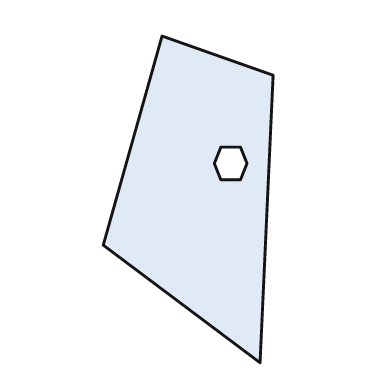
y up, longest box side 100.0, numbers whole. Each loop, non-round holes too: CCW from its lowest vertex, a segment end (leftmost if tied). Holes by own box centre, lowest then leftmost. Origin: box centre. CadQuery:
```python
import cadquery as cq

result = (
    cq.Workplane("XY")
    .moveTo(22.0, -50.0)
    .lineTo(26.0, 38.0)
    .lineTo(-8.0, 50.0)
    .lineTo(-26.0, -14.0)
    .close()
    .moveTo(10.0, 6.0)
    .lineTo(16.0, 6.0)
    .lineTo(18.0, 11.0)
    .lineTo(16.0, 16.0)
    .lineTo(10.0, 16.0)
    .lineTo(8.0, 11.0)
    .close()
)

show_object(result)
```